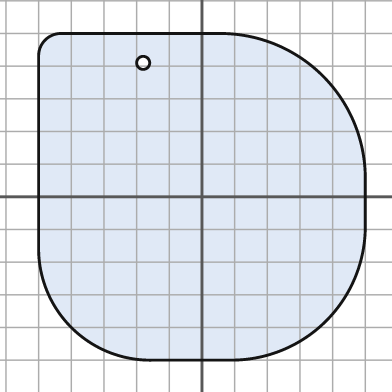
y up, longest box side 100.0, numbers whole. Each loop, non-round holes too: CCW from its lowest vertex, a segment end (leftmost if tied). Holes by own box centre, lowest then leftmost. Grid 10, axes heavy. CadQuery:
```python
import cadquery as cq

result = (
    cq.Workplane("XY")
    .moveTo(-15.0, -50.0)
    .lineTo(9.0, -50.0)
    .threePointArc((38.0, -38.0), (50.0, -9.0))
    .lineTo(50.0, 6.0)
    .threePointArc((37.0, 37.0), (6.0, 50.0))
    .lineTo(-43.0, 50.0)
    .threePointArc((-48.0, 48.0), (-50.0, 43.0))
    .lineTo(-50.0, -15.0)
    .threePointArc((-40.0, -40.0), (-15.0, -50.0))
    .close()
    .moveTo(-18.0, 41.0)
    .circle(2.0)
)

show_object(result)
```